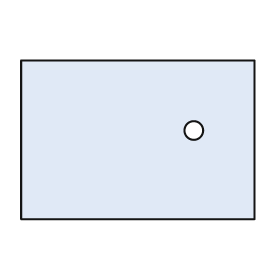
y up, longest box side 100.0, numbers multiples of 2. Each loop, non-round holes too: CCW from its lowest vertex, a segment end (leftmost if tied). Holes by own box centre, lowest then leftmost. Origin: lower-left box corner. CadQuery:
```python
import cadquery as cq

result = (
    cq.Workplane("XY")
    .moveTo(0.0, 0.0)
    .lineTo(100.0, 0.0)
    .lineTo(100.0, 68.0)
    .lineTo(0.0, 68.0)
    .close()
    .moveTo(74.0, 38.0)
    .circle(4.0)
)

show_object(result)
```